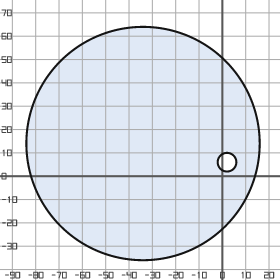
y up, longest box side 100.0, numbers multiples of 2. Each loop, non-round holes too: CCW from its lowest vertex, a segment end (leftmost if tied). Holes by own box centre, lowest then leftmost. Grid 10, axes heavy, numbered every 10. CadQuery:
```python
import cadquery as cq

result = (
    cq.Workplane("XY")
    .moveTo(-34.0, 14.0)
    .circle(50.0)
    .moveTo(2.0, 6.0)
    .circle(4.0)
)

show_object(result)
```